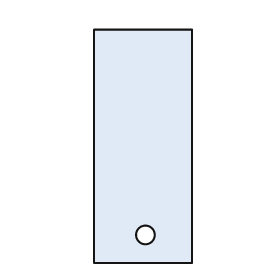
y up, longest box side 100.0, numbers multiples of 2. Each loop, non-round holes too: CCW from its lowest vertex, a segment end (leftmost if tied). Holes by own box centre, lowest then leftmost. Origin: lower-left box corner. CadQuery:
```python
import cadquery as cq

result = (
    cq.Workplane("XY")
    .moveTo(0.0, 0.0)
    .lineTo(42.0, 0.0)
    .lineTo(42.0, 100.0)
    .lineTo(0.0, 100.0)
    .close()
    .moveTo(22.0, 12.0)
    .circle(4.0)
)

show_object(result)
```